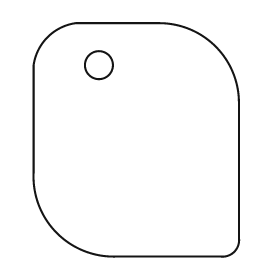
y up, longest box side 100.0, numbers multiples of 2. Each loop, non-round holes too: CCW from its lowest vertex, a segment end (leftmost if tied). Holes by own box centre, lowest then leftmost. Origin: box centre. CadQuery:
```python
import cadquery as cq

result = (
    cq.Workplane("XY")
    .moveTo(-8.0, -50.0)
    .lineTo(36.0, -50.0)
    .threePointArc((42.0, -48.0), (44.0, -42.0))
    .lineTo(44.0, 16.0)
    .threePointArc((34.0, 40.0), (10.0, 50.0))
    .lineTo(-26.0, 50.0)
    .threePointArc((-38.0, 44.0), (-44.0, 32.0))
    .lineTo(-44.0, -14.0)
    .threePointArc((-34.0, -40.0), (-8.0, -50.0))
    .close()
    .moveTo(-16.0, 32.0)
    .circle(6.0)
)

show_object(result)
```